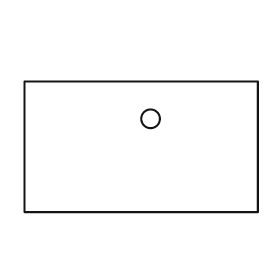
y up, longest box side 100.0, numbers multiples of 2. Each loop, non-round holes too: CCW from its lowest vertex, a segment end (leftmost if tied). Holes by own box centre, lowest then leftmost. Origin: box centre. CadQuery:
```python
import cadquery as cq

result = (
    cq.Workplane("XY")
    .moveTo(-50.0, -28.0)
    .lineTo(50.0, -28.0)
    .lineTo(50.0, 28.0)
    .lineTo(-50.0, 28.0)
    .close()
    .moveTo(4.0, 12.0)
    .circle(4.0)
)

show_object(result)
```